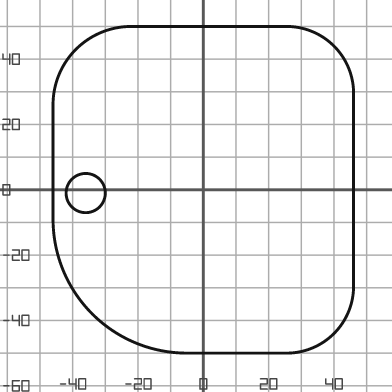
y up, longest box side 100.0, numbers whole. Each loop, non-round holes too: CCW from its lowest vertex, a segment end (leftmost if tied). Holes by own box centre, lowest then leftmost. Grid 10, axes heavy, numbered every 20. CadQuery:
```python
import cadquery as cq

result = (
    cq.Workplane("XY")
    .moveTo(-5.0, -50.0)
    .lineTo(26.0, -50.0)
    .threePointArc((40.0, -44.0), (46.0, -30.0))
    .lineTo(46.0, 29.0)
    .threePointArc((40.0, 44.0), (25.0, 50.0))
    .lineTo(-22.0, 50.0)
    .threePointArc((-39.0, 43.0), (-46.0, 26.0))
    .lineTo(-46.0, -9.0)
    .threePointArc((-34.0, -38.0), (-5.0, -50.0))
    .close()
    .moveTo(-36.0, -1.0)
    .circle(6.0)
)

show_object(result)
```